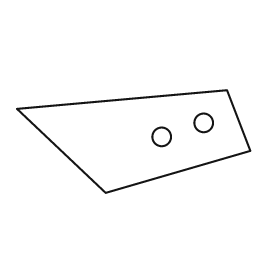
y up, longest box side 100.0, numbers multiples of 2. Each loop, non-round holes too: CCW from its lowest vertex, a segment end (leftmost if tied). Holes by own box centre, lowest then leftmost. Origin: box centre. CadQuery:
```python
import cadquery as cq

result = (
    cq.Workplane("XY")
    .moveTo(-12.0, -22.0)
    .lineTo(50.0, -4.0)
    .lineTo(40.0, 22.0)
    .lineTo(-50.0, 14.0)
    .close()
    .moveTo(12.0, 2.0)
    .circle(4.0)
    .moveTo(30.0, 8.0)
    .circle(4.0)
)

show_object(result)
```